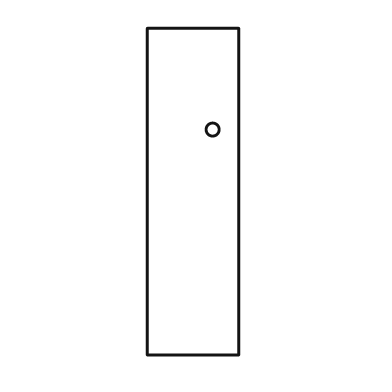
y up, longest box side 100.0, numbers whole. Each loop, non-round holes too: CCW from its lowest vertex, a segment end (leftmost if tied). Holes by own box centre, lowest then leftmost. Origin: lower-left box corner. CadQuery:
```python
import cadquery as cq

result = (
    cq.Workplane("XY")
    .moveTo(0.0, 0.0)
    .lineTo(28.0, 0.0)
    .lineTo(28.0, 100.0)
    .lineTo(0.0, 100.0)
    .close()
    .moveTo(20.0, 69.0)
    .circle(2.0)
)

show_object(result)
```